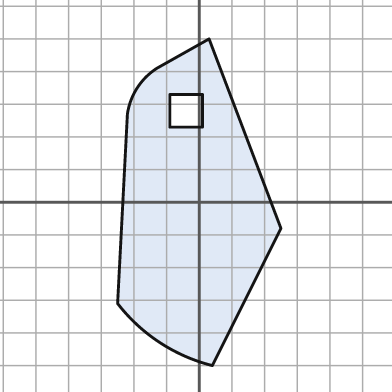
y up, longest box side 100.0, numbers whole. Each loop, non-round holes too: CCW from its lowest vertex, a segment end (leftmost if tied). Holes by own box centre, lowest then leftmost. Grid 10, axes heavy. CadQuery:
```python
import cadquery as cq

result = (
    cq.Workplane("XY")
    .moveTo(4.0, -50.0)
    .lineTo(25.0, -8.0)
    .lineTo(3.0, 50.0)
    .lineTo(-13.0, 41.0)
    .threePointArc((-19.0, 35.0), (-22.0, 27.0))
    .lineTo(-25.0, -31.0)
    .threePointArc((-12.0, -43.0), (4.0, -50.0))
    .close()
    .moveTo(-9.0, 23.0)
    .lineTo(1.0, 23.0)
    .lineTo(1.0, 33.0)
    .lineTo(-9.0, 33.0)
    .close()
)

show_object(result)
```